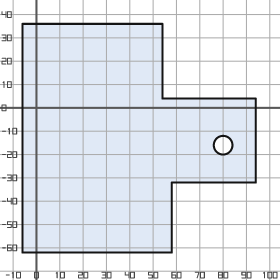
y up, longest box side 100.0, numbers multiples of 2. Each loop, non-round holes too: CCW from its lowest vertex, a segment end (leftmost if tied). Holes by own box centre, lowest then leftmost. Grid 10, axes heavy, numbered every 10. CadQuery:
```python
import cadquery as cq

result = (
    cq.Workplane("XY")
    .moveTo(-6.0, -62.0)
    .lineTo(58.0, -62.0)
    .lineTo(58.0, -32.0)
    .lineTo(94.0, -32.0)
    .lineTo(94.0, 4.0)
    .lineTo(54.0, 4.0)
    .lineTo(54.0, 36.0)
    .lineTo(-6.0, 36.0)
    .close()
    .moveTo(80.0, -16.0)
    .circle(4.0)
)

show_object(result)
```